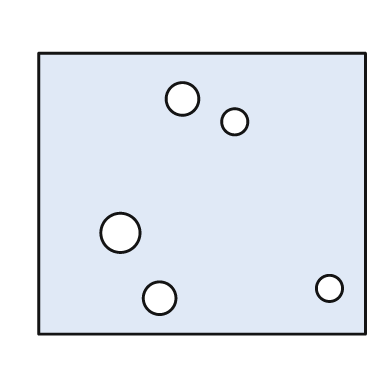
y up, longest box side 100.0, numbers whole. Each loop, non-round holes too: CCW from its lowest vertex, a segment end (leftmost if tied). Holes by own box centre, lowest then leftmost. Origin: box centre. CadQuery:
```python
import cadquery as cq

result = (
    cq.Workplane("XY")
    .moveTo(-50.0, -43.0)
    .lineTo(50.0, -43.0)
    .lineTo(50.0, 43.0)
    .lineTo(-50.0, 43.0)
    .close()
    .moveTo(-13.0, -32.0)
    .circle(5.0)
    .moveTo(39.0, -29.0)
    .circle(4.0)
    .moveTo(-25.0, -12.0)
    .circle(6.0)
    .moveTo(10.0, 22.0)
    .circle(4.0)
    .moveTo(-6.0, 29.0)
    .circle(5.0)
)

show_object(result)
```